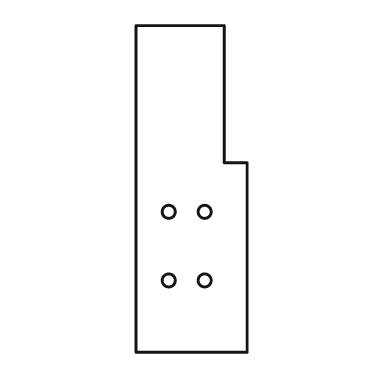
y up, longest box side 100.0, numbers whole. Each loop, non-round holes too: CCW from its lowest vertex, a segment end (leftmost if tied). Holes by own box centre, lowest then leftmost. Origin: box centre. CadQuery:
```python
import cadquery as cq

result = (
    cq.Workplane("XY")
    .moveTo(-17.0, -50.0)
    .lineTo(17.0, -50.0)
    .lineTo(17.0, 8.0)
    .lineTo(10.0, 8.0)
    .lineTo(10.0, 50.0)
    .lineTo(-17.0, 50.0)
    .close()
    .moveTo(-7.0, -28.0)
    .circle(2.0)
    .moveTo(4.0, -28.0)
    .circle(2.0)
    .moveTo(-7.0, -7.0)
    .circle(2.0)
    .moveTo(4.0, -7.0)
    .circle(2.0)
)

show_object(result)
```